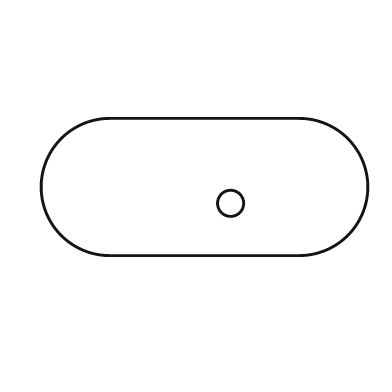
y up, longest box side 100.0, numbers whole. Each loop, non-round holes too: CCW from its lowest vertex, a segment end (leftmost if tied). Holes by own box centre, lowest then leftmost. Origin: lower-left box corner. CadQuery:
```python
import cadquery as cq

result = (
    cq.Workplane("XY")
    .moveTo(21.0, 0.0)
    .lineTo(79.0, 0.0)
    .threePointArc((100.0, 21.0), (79.0, 42.0))
    .lineTo(21.0, 42.0)
    .threePointArc((0.0, 21.0), (21.0, 0.0))
    .close()
    .moveTo(58.0, 16.0)
    .circle(4.0)
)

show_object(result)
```